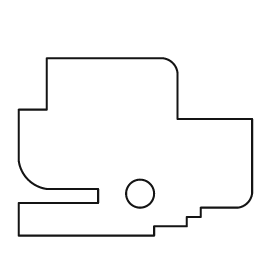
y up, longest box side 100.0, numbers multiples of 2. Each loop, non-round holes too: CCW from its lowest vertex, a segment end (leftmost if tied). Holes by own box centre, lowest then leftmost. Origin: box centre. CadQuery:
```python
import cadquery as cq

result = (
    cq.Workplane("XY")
    .moveTo(-50.0, -38.0)
    .lineTo(8.0, -38.0)
    .lineTo(8.0, -34.0)
    .lineTo(22.0, -34.0)
    .lineTo(22.0, -30.0)
    .lineTo(28.0, -30.0)
    .lineTo(28.0, -26.0)
    .lineTo(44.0, -26.0)
    .threePointArc((48.0, -24.0), (50.0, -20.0))
    .lineTo(50.0, 12.0)
    .lineTo(18.0, 12.0)
    .lineTo(18.0, 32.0)
    .threePointArc((16.0, 36.0), (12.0, 38.0))
    .lineTo(-38.0, 38.0)
    .lineTo(-38.0, 16.0)
    .lineTo(-50.0, 16.0)
    .lineTo(-50.0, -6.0)
    .threePointArc((-46.0, -14.0), (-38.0, -18.0))
    .lineTo(-16.0, -18.0)
    .lineTo(-16.0, -24.0)
    .lineTo(-50.0, -24.0)
    .close()
    .moveTo(2.0, -20.0)
    .circle(6.0)
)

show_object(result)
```